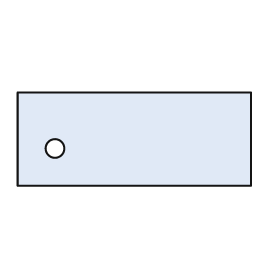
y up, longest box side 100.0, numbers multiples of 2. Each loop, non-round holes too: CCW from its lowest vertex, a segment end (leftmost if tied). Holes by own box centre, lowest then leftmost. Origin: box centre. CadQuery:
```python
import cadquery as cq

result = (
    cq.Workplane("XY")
    .moveTo(-50.0, -20.0)
    .lineTo(50.0, -20.0)
    .lineTo(50.0, 20.0)
    .lineTo(-50.0, 20.0)
    .close()
    .moveTo(-34.0, -4.0)
    .circle(4.0)
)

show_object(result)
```